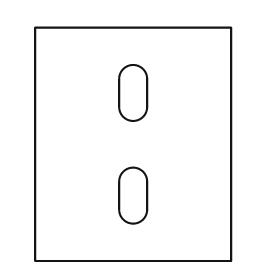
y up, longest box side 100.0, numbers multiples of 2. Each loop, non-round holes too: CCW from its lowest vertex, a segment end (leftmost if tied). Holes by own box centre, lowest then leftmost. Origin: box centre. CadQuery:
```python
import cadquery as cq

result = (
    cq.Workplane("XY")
    .moveTo(-42.0, -50.0)
    .lineTo(42.0, -50.0)
    .lineTo(42.0, 50.0)
    .lineTo(-42.0, 50.0)
    .close()
    .moveTo(-6.0, -28.0)
    .threePointArc((0.0, -34.0), (6.0, -28.0))
    .lineTo(6.0, -16.0)
    .threePointArc((0.0, -10.0), (-6.0, -16.0))
    .close()
    .moveTo(-6.0, 16.0)
    .threePointArc((0.0, 10.0), (6.0, 16.0))
    .lineTo(6.0, 28.0)
    .threePointArc((0.0, 34.0), (-6.0, 28.0))
    .close()
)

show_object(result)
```